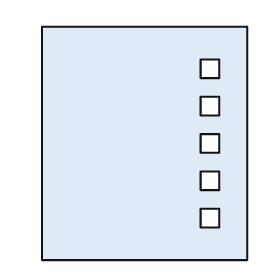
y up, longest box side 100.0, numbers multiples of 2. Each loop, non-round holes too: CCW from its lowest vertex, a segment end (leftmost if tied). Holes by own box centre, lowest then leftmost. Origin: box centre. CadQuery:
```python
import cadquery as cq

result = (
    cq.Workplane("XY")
    .moveTo(-44.0, -50.0)
    .lineTo(44.0, -50.0)
    .lineTo(44.0, 50.0)
    .lineTo(-44.0, 50.0)
    .close()
    .moveTo(24.0, -36.0)
    .lineTo(32.0, -36.0)
    .lineTo(32.0, -28.0)
    .lineTo(24.0, -28.0)
    .close()
    .moveTo(24.0, -20.0)
    .lineTo(32.0, -20.0)
    .lineTo(32.0, -12.0)
    .lineTo(24.0, -12.0)
    .close()
    .moveTo(24.0, -4.0)
    .lineTo(32.0, -4.0)
    .lineTo(32.0, 4.0)
    .lineTo(24.0, 4.0)
    .close()
    .moveTo(24.0, 12.0)
    .lineTo(32.0, 12.0)
    .lineTo(32.0, 20.0)
    .lineTo(24.0, 20.0)
    .close()
    .moveTo(24.0, 28.0)
    .lineTo(32.0, 28.0)
    .lineTo(32.0, 36.0)
    .lineTo(24.0, 36.0)
    .close()
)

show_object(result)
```